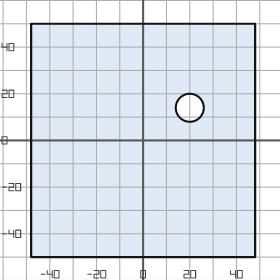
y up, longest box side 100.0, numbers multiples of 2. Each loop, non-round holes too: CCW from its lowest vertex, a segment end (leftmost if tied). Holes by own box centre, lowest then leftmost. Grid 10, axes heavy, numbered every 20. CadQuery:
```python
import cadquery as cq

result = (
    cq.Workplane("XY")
    .moveTo(-48.0, -50.0)
    .lineTo(48.0, -50.0)
    .lineTo(48.0, 50.0)
    .lineTo(-48.0, 50.0)
    .close()
    .moveTo(20.0, 14.0)
    .circle(6.0)
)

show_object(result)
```